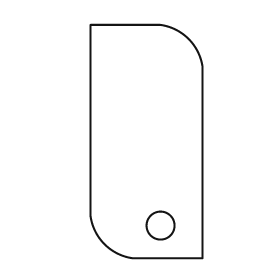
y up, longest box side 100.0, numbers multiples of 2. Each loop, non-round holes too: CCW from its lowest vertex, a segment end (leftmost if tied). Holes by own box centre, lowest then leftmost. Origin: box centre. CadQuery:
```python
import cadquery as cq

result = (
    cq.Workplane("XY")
    .moveTo(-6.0, -50.0)
    .lineTo(24.0, -50.0)
    .lineTo(24.0, 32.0)
    .threePointArc((18.0, 44.0), (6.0, 50.0))
    .lineTo(-24.0, 50.0)
    .lineTo(-24.0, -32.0)
    .threePointArc((-18.0, -44.0), (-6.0, -50.0))
    .close()
    .moveTo(6.0, -36.0)
    .circle(6.0)
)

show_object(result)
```